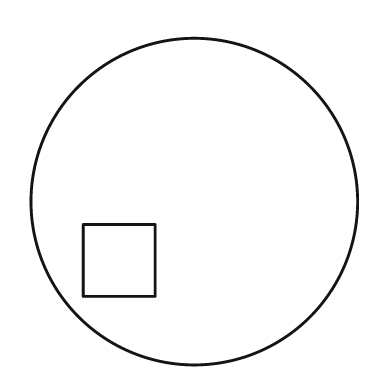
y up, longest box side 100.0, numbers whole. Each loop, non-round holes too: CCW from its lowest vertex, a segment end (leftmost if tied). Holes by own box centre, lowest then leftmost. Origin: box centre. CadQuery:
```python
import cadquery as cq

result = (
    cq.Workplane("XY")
    .moveTo(0.0, 0.0)
    .circle(50.0)
    .moveTo(-34.0, -29.0)
    .lineTo(-12.0, -29.0)
    .lineTo(-12.0, -7.0)
    .lineTo(-34.0, -7.0)
    .close()
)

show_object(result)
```